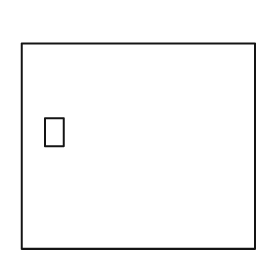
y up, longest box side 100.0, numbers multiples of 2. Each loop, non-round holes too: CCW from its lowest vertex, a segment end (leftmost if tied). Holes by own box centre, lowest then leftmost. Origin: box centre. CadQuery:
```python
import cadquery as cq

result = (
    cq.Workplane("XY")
    .moveTo(-50.0, -44.0)
    .lineTo(50.0, -44.0)
    .lineTo(50.0, 44.0)
    .lineTo(-50.0, 44.0)
    .close()
    .moveTo(-40.0, 0.0)
    .lineTo(-32.0, 0.0)
    .lineTo(-32.0, 12.0)
    .lineTo(-40.0, 12.0)
    .close()
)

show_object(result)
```